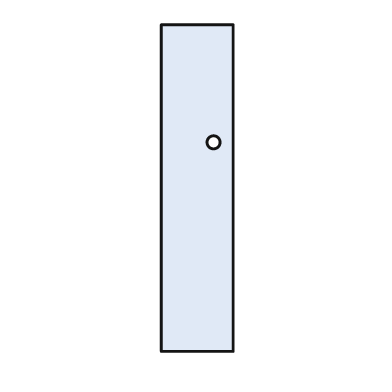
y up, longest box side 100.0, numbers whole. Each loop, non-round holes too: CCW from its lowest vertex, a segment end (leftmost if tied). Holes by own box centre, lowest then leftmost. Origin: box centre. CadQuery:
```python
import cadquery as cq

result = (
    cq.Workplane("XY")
    .moveTo(-11.0, -50.0)
    .lineTo(11.0, -50.0)
    .lineTo(11.0, 50.0)
    .lineTo(-11.0, 50.0)
    .close()
    .moveTo(5.0, 14.0)
    .circle(2.0)
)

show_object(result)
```